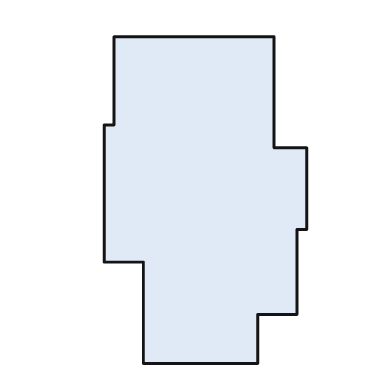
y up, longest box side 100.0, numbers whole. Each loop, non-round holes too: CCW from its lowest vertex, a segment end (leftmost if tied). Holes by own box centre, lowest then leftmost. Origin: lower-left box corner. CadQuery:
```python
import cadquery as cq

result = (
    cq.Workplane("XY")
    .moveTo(12.0, 0.0)
    .lineTo(47.0, 0.0)
    .lineTo(47.0, 15.0)
    .lineTo(59.0, 15.0)
    .lineTo(59.0, 41.0)
    .lineTo(62.0, 41.0)
    .lineTo(62.0, 66.0)
    .lineTo(52.0, 66.0)
    .lineTo(52.0, 100.0)
    .lineTo(3.0, 100.0)
    .lineTo(3.0, 73.0)
    .lineTo(0.0, 73.0)
    .lineTo(0.0, 31.0)
    .lineTo(12.0, 31.0)
    .close()
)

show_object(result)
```